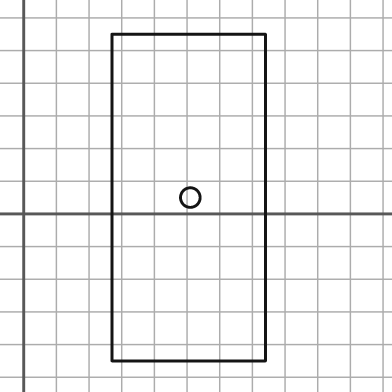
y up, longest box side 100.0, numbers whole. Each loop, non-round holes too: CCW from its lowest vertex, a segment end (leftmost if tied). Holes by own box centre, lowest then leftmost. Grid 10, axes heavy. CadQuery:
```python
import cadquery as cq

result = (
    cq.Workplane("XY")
    .moveTo(27.0, -45.0)
    .lineTo(74.0, -45.0)
    .lineTo(74.0, 55.0)
    .lineTo(27.0, 55.0)
    .close()
    .moveTo(51.0, 5.0)
    .circle(3.0)
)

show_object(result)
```